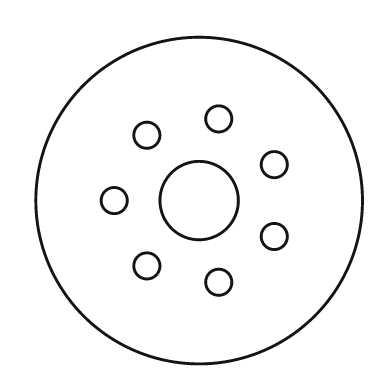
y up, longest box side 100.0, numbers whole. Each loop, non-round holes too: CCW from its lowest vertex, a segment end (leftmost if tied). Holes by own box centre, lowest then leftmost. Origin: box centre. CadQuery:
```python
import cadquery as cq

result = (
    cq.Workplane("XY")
    .moveTo(0.0, 0.0)
    .circle(50.0)
    .moveTo(6.0, -25.0)
    .circle(4.0)
    .moveTo(-16.0, -20.0)
    .circle(4.0)
    .moveTo(23.0, -11.0)
    .circle(4.0)
    .moveTo(-26.0, 0.0)
    .circle(4.0)
    .moveTo(0.0, 0.0)
    .circle(12.0)
    .moveTo(23.0, 11.0)
    .circle(4.0)
    .moveTo(-16.0, 20.0)
    .circle(4.0)
    .moveTo(6.0, 25.0)
    .circle(4.0)
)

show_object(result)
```